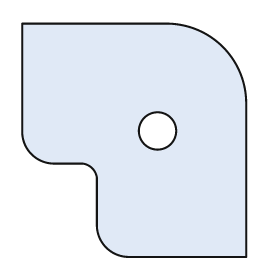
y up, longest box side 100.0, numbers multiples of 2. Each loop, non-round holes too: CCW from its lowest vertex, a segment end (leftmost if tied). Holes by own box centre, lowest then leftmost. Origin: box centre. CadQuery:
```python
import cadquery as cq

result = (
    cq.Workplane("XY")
    .moveTo(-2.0, -50.0)
    .lineTo(48.0, -50.0)
    .lineTo(48.0, 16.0)
    .threePointArc((38.0, 40.0), (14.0, 50.0))
    .lineTo(-48.0, 50.0)
    .lineTo(-48.0, 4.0)
    .threePointArc((-44.0, -6.0), (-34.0, -10.0))
    .lineTo(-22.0, -10.0)
    .threePointArc((-18.0, -12.0), (-16.0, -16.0))
    .lineTo(-16.0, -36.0)
    .threePointArc((-12.0, -46.0), (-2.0, -50.0))
    .close()
    .moveTo(10.0, 4.0)
    .circle(8.0)
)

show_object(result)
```